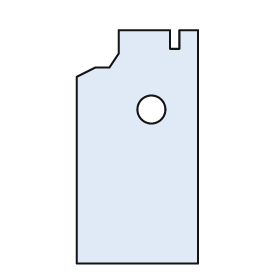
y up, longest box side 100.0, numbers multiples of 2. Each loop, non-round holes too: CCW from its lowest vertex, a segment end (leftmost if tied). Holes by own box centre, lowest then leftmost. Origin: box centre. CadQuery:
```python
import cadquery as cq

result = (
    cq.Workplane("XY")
    .moveTo(-26.0, -50.0)
    .lineTo(26.0, -50.0)
    .lineTo(26.0, 50.0)
    .lineTo(18.0, 50.0)
    .lineTo(18.0, 42.0)
    .lineTo(14.0, 42.0)
    .lineTo(14.0, 50.0)
    .lineTo(-8.0, 50.0)
    .lineTo(-8.0, 40.0)
    .lineTo(-12.0, 34.0)
    .lineTo(-18.0, 34.0)
    .lineTo(-26.0, 30.0)
    .close()
    .moveTo(6.0, 16.0)
    .circle(6.0)
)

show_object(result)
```